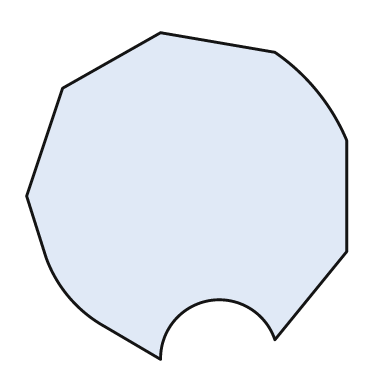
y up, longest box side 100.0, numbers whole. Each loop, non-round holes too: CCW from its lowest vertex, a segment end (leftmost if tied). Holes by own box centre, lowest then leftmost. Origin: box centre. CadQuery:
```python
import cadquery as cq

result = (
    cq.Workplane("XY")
    .moveTo(-8.0, -50.0)
    .threePointArc((7.0, -32.0), (27.0, -44.0))
    .lineTo(49.0, -17.0)
    .lineTo(49.0, 17.0)
    .threePointArc((40.0, 32.0), (27.0, 44.0))
    .lineTo(-8.0, 50.0)
    .lineTo(-38.0, 33.0)
    .lineTo(-49.0, 0.0)
    .lineTo(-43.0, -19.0)
    .threePointArc((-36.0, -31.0), (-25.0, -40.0))
    .close()
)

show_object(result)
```